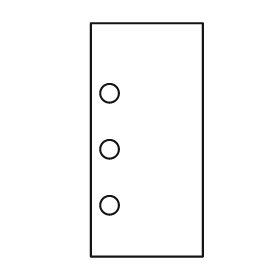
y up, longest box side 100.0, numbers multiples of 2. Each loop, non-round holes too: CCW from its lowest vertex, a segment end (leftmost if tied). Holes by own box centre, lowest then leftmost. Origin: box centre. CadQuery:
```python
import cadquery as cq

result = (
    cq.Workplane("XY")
    .moveTo(-24.0, -50.0)
    .lineTo(24.0, -50.0)
    .lineTo(24.0, 50.0)
    .lineTo(-24.0, 50.0)
    .close()
    .moveTo(-16.0, -28.0)
    .circle(4.0)
    .moveTo(-16.0, -4.0)
    .circle(4.0)
    .moveTo(-16.0, 20.0)
    .circle(4.0)
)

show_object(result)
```